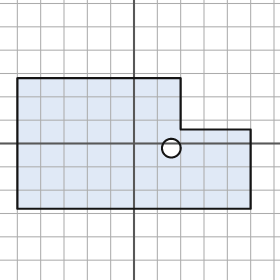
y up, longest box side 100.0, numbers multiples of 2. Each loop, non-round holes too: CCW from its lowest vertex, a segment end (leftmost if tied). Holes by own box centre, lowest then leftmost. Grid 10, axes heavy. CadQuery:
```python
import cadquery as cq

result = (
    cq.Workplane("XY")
    .moveTo(-50.0, -28.0)
    .lineTo(50.0, -28.0)
    .lineTo(50.0, 6.0)
    .lineTo(20.0, 6.0)
    .lineTo(20.0, 28.0)
    .lineTo(-50.0, 28.0)
    .close()
    .moveTo(16.0, -2.0)
    .circle(4.0)
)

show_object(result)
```